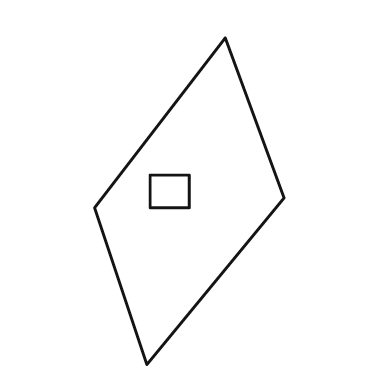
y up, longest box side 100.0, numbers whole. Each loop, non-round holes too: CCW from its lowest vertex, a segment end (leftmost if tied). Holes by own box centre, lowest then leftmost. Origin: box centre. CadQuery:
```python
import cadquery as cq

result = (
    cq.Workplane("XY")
    .moveTo(-13.0, -50.0)
    .lineTo(29.0, 1.0)
    .lineTo(11.0, 50.0)
    .lineTo(-29.0, -2.0)
    .close()
    .moveTo(-12.0, -2.0)
    .lineTo(0.0, -2.0)
    .lineTo(0.0, 8.0)
    .lineTo(-12.0, 8.0)
    .close()
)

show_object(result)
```